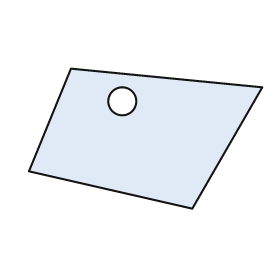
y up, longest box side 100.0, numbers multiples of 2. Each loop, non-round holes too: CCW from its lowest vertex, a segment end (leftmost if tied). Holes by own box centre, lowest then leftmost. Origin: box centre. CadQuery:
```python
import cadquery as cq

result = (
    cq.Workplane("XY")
    .moveTo(20.0, -30.0)
    .lineTo(50.0, 22.0)
    .lineTo(-32.0, 30.0)
    .lineTo(-50.0, -14.0)
    .close()
    .moveTo(-10.0, 16.0)
    .circle(6.0)
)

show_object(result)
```